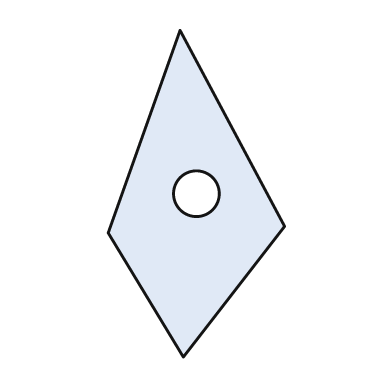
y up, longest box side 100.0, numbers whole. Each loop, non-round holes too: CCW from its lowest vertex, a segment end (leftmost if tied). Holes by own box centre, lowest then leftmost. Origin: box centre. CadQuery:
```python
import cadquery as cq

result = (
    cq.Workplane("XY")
    .moveTo(-4.0, -50.0)
    .lineTo(27.0, -10.0)
    .lineTo(-5.0, 50.0)
    .lineTo(-27.0, -12.0)
    .close()
    .moveTo(0.0, 0.0)
    .circle(7.0)
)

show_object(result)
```